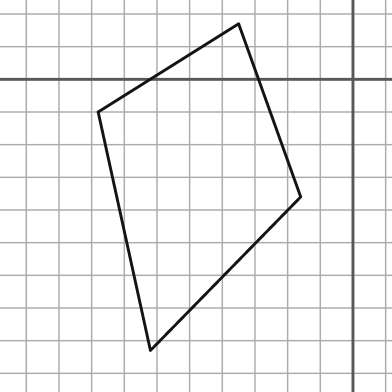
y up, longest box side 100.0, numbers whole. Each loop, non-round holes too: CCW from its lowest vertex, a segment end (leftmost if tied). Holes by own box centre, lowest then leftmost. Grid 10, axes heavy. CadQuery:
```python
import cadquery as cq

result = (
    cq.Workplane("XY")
    .moveTo(-62.0, -83.0)
    .lineTo(-16.0, -36.0)
    .lineTo(-35.0, 17.0)
    .lineTo(-78.0, -10.0)
    .close()
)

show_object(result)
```